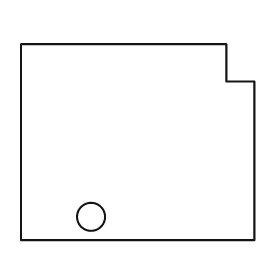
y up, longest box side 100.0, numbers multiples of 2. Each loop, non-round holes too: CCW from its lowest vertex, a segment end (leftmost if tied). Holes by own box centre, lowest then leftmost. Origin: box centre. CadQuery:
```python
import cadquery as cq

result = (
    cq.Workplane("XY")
    .moveTo(-50.0, -42.0)
    .lineTo(50.0, -42.0)
    .lineTo(50.0, 26.0)
    .lineTo(38.0, 26.0)
    .lineTo(38.0, 42.0)
    .lineTo(-50.0, 42.0)
    .close()
    .moveTo(-20.0, -32.0)
    .circle(6.0)
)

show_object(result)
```